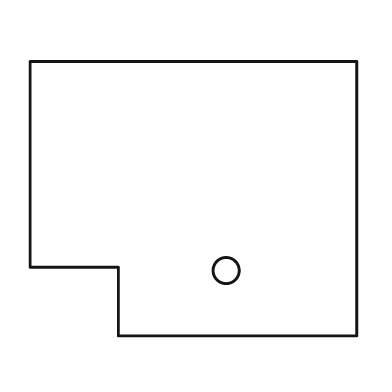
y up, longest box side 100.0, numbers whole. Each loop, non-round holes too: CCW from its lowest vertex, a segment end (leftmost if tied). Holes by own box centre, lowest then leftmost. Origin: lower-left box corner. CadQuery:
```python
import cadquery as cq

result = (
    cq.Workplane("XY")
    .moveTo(27.0, 0.0)
    .lineTo(100.0, 0.0)
    .lineTo(100.0, 84.0)
    .lineTo(0.0, 84.0)
    .lineTo(0.0, 21.0)
    .lineTo(27.0, 21.0)
    .close()
    .moveTo(60.0, 20.0)
    .circle(4.0)
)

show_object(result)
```